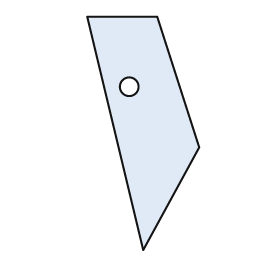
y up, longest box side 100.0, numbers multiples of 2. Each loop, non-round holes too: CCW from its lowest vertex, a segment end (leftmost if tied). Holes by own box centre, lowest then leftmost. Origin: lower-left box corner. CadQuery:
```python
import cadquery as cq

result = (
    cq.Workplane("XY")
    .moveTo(24.0, 0.0)
    .lineTo(48.0, 44.0)
    .lineTo(30.0, 100.0)
    .lineTo(0.0, 100.0)
    .close()
    .moveTo(18.0, 70.0)
    .circle(4.0)
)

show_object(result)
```